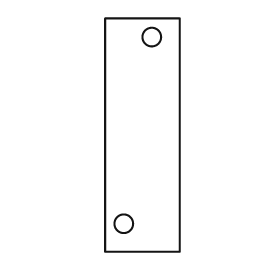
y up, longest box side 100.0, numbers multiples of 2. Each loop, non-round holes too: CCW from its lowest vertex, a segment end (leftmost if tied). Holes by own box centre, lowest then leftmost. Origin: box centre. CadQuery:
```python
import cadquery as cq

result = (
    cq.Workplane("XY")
    .moveTo(-16.0, -50.0)
    .lineTo(16.0, -50.0)
    .lineTo(16.0, 50.0)
    .lineTo(-16.0, 50.0)
    .close()
    .moveTo(-8.0, -38.0)
    .circle(4.0)
    .moveTo(4.0, 42.0)
    .circle(4.0)
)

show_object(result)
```